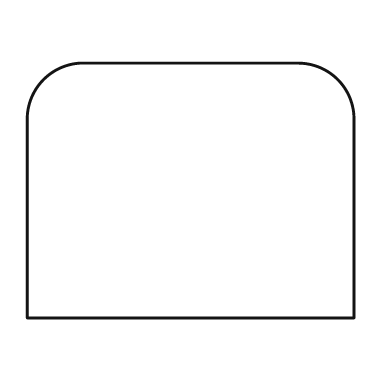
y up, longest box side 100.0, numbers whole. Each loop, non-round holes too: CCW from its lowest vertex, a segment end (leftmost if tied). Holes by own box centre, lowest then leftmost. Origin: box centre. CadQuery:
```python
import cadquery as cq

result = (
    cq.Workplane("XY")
    .moveTo(-50.0, -39.0)
    .lineTo(50.0, -39.0)
    .lineTo(50.0, 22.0)
    .threePointArc((45.0, 34.0), (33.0, 39.0))
    .lineTo(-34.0, 39.0)
    .threePointArc((-45.0, 34.0), (-50.0, 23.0))
    .close()
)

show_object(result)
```